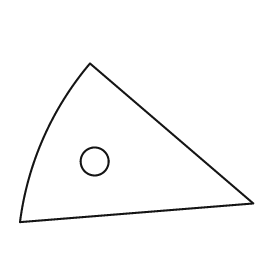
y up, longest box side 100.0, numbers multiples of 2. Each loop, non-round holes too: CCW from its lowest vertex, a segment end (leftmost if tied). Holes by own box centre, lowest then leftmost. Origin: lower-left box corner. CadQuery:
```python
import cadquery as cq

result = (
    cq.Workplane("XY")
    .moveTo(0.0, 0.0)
    .lineTo(100.0, 8.0)
    .lineTo(30.0, 68.0)
    .threePointArc((10.0, 36.0), (0.0, 0.0))
    .close()
    .moveTo(32.0, 26.0)
    .circle(6.0)
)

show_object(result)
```